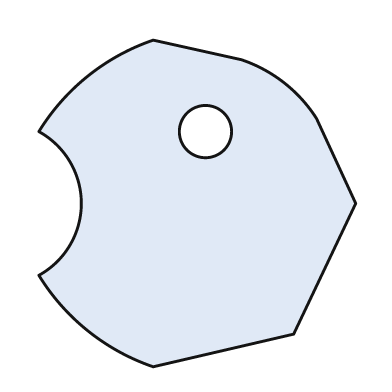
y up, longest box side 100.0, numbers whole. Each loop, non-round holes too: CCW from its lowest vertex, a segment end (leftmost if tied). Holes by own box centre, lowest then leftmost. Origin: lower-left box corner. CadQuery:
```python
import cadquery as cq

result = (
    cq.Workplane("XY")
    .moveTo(35.0, 0.0)
    .lineTo(78.0, 10.0)
    .lineTo(97.0, 50.0)
    .lineTo(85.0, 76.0)
    .threePointArc((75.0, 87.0), (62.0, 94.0))
    .lineTo(35.0, 100.0)
    .threePointArc((15.0, 89.0), (0.0, 72.0))
    .threePointArc((13.0, 50.0), (0.0, 28.0))
    .threePointArc((15.0, 11.0), (35.0, 0.0))
    .close()
    .moveTo(51.0, 72.0)
    .circle(8.0)
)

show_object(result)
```